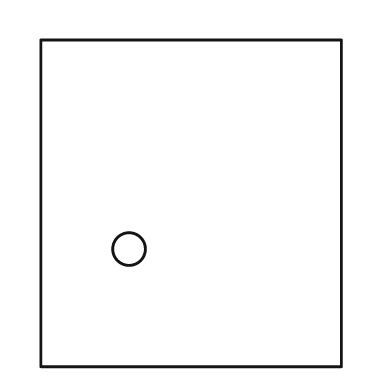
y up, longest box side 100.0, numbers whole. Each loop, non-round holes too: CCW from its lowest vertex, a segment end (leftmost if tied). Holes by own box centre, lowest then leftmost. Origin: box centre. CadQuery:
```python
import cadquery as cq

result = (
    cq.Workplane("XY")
    .moveTo(-46.0, -50.0)
    .lineTo(46.0, -50.0)
    .lineTo(46.0, 50.0)
    .lineTo(-46.0, 50.0)
    .close()
    .moveTo(-19.0, -14.0)
    .circle(5.0)
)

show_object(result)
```